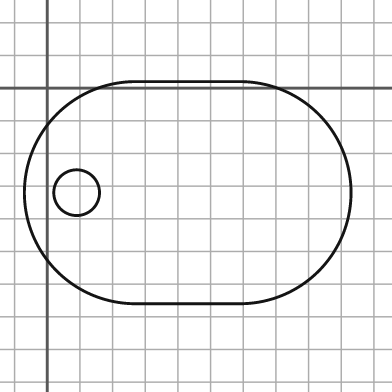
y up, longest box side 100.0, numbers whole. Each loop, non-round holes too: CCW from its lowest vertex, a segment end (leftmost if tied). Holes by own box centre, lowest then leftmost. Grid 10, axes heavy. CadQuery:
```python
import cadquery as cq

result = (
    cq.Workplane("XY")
    .moveTo(27.0, -66.0)
    .lineTo(59.0, -66.0)
    .threePointArc((93.0, -32.0), (59.0, 2.0))
    .lineTo(27.0, 2.0)
    .threePointArc((-7.0, -32.0), (27.0, -66.0))
    .close()
    .moveTo(9.0, -32.0)
    .circle(7.0)
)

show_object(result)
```